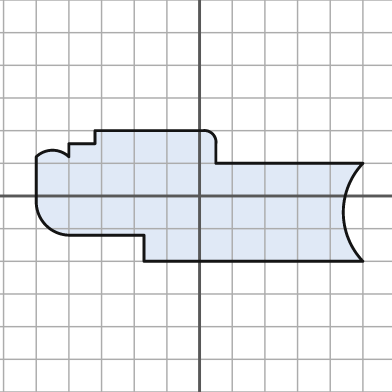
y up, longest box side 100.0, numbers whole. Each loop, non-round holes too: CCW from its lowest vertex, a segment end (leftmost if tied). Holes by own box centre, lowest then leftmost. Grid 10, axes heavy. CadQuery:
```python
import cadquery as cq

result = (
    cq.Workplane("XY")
    .moveTo(-17.0, -20.0)
    .lineTo(50.0, -20.0)
    .threePointArc((44.0, -5.0), (50.0, 10.0))
    .lineTo(5.0, 10.0)
    .lineTo(5.0, 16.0)
    .threePointArc((4.0, 19.0), (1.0, 20.0))
    .lineTo(-32.0, 20.0)
    .lineTo(-32.0, 16.0)
    .lineTo(-40.0, 16.0)
    .lineTo(-40.0, 12.0)
    .threePointArc((-45.0, 14.0), (-50.0, 12.0))
    .lineTo(-50.0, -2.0)
    .threePointArc((-47.0, -9.0), (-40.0, -12.0))
    .lineTo(-17.0, -12.0)
    .close()
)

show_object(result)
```